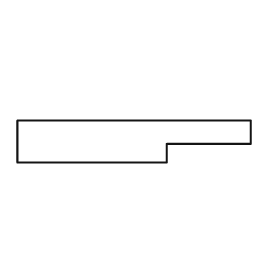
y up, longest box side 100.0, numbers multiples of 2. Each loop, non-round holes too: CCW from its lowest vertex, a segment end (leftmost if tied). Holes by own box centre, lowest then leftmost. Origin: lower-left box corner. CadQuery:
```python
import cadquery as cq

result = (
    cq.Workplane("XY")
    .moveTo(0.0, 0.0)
    .lineTo(64.0, 0.0)
    .lineTo(64.0, 8.0)
    .lineTo(100.0, 8.0)
    .lineTo(100.0, 18.0)
    .lineTo(0.0, 18.0)
    .close()
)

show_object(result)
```